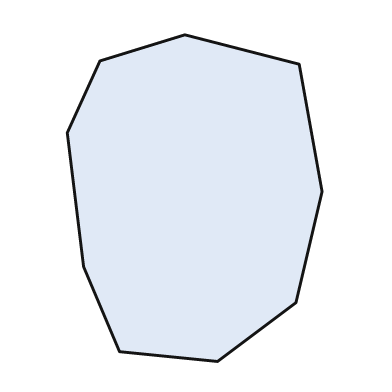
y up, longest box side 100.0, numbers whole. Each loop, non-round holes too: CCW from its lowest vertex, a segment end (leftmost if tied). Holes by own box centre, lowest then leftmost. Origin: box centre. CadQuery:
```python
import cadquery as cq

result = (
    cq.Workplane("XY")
    .moveTo(7.0, -50.0)
    .lineTo(31.0, -32.0)
    .lineTo(39.0, 2.0)
    .lineTo(32.0, 41.0)
    .lineTo(-3.0, 50.0)
    .lineTo(-29.0, 42.0)
    .lineTo(-39.0, 20.0)
    .lineTo(-34.0, -21.0)
    .lineTo(-23.0, -47.0)
    .close()
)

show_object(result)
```